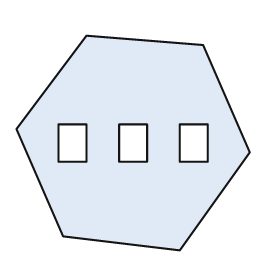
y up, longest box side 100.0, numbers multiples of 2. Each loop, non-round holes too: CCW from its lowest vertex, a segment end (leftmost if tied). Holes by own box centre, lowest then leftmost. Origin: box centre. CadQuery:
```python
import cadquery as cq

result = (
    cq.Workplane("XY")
    .moveTo(20.0, -46.0)
    .lineTo(50.0, -4.0)
    .lineTo(30.0, 42.0)
    .lineTo(-20.0, 46.0)
    .lineTo(-50.0, 6.0)
    .lineTo(-30.0, -40.0)
    .close()
    .moveTo(-32.0, -8.0)
    .lineTo(-20.0, -8.0)
    .lineTo(-20.0, 8.0)
    .lineTo(-32.0, 8.0)
    .close()
    .moveTo(-6.0, -8.0)
    .lineTo(6.0, -8.0)
    .lineTo(6.0, 8.0)
    .lineTo(-6.0, 8.0)
    .close()
    .moveTo(20.0, -8.0)
    .lineTo(32.0, -8.0)
    .lineTo(32.0, 8.0)
    .lineTo(20.0, 8.0)
    .close()
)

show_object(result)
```